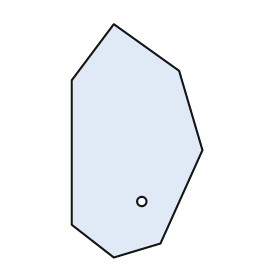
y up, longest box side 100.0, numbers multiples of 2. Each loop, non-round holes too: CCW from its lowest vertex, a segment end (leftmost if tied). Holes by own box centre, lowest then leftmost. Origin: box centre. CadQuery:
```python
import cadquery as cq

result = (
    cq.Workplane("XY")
    .moveTo(-10.0, -50.0)
    .lineTo(10.0, -44.0)
    .lineTo(28.0, -4.0)
    .lineTo(18.0, 30.0)
    .lineTo(-10.0, 50.0)
    .lineTo(-28.0, 26.0)
    .lineTo(-28.0, -36.0)
    .close()
    .moveTo(2.0, -26.0)
    .circle(2.0)
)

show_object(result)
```